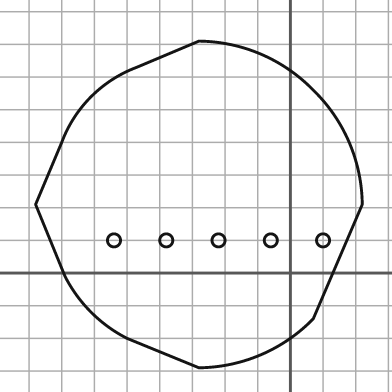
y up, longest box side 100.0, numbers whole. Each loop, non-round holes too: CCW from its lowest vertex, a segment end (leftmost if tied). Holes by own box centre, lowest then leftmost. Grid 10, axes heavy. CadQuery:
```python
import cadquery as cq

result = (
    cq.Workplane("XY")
    .moveTo(-28.0, -29.0)
    .threePointArc((-9.0, -25.0), (7.0, -14.0))
    .lineTo(22.0, 21.0)
    .threePointArc((18.0, 40.0), (7.0, 56.0))
    .threePointArc((-9.0, 67.0), (-28.0, 71.0))
    .lineTo(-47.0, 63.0)
    .threePointArc((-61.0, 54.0), (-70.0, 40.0))
    .lineTo(-78.0, 21.0)
    .lineTo(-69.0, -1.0)
    .threePointArc((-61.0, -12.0), (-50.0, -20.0))
    .close()
    .moveTo(-54.0, 10.0)
    .circle(2.0)
    .moveTo(-38.0, 10.0)
    .circle(2.0)
    .moveTo(-22.0, 10.0)
    .circle(2.0)
    .moveTo(-6.0, 10.0)
    .circle(2.0)
    .moveTo(10.0, 10.0)
    .circle(2.0)
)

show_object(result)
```